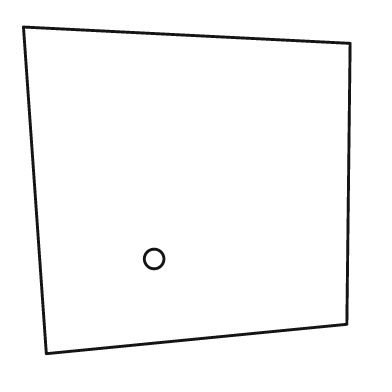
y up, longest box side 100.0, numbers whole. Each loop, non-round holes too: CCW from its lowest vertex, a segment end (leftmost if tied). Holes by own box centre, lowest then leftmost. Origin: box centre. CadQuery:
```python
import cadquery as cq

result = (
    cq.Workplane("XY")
    .moveTo(-43.0, -50.0)
    .lineTo(49.0, -41.0)
    .lineTo(50.0, 45.0)
    .lineTo(-50.0, 50.0)
    .close()
    .moveTo(-10.0, -21.0)
    .circle(3.0)
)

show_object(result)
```